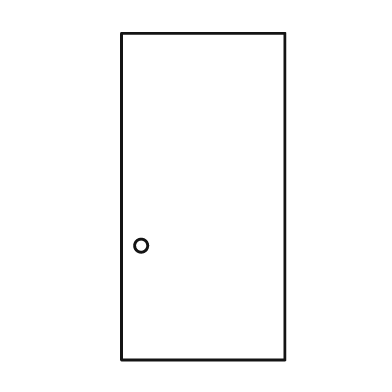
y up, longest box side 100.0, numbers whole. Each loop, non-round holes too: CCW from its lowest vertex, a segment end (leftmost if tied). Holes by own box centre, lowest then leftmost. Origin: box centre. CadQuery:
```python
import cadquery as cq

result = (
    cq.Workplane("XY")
    .moveTo(-25.0, -50.0)
    .lineTo(25.0, -50.0)
    .lineTo(25.0, 50.0)
    .lineTo(-25.0, 50.0)
    .close()
    .moveTo(-19.0, -15.0)
    .circle(2.0)
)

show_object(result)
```